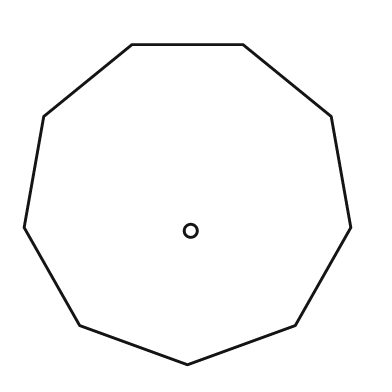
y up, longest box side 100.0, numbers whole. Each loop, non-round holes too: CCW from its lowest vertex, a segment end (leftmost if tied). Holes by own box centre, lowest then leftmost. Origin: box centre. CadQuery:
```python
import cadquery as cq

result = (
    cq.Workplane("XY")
    .moveTo(0.0, -49.0)
    .lineTo(33.0, -37.0)
    .lineTo(50.0, -7.0)
    .lineTo(44.0, 27.0)
    .lineTo(17.0, 49.0)
    .lineTo(-17.0, 49.0)
    .lineTo(-44.0, 27.0)
    .lineTo(-50.0, -7.0)
    .lineTo(-33.0, -37.0)
    .close()
    .moveTo(1.0, -8.0)
    .circle(2.0)
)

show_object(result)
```